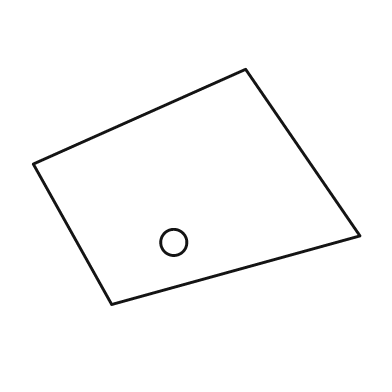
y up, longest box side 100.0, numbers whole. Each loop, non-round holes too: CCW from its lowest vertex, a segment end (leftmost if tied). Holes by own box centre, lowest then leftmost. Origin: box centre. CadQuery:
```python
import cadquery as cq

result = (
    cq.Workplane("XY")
    .moveTo(-26.0, -36.0)
    .lineTo(50.0, -15.0)
    .lineTo(15.0, 36.0)
    .lineTo(-50.0, 7.0)
    .close()
    .moveTo(-7.0, -17.0)
    .circle(4.0)
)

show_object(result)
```